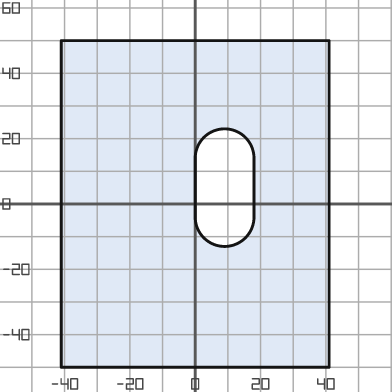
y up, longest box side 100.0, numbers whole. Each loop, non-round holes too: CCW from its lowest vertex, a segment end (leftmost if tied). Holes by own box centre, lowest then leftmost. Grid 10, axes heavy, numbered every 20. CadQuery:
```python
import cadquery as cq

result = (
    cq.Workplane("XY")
    .moveTo(-41.0, -50.0)
    .lineTo(41.0, -50.0)
    .lineTo(41.0, 50.0)
    .lineTo(-41.0, 50.0)
    .close()
    .moveTo(0.0, -4.0)
    .threePointArc((9.0, -13.0), (18.0, -4.0))
    .lineTo(18.0, 14.0)
    .threePointArc((9.0, 23.0), (0.0, 14.0))
    .close()
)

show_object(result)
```